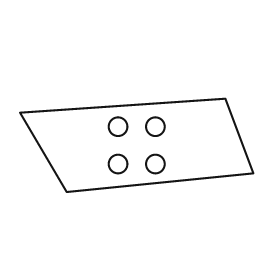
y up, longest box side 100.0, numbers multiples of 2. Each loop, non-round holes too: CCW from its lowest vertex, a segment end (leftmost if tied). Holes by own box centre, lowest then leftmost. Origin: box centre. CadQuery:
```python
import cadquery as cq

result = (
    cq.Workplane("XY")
    .moveTo(-30.0, -20.0)
    .lineTo(50.0, -12.0)
    .lineTo(38.0, 20.0)
    .lineTo(-50.0, 14.0)
    .close()
    .moveTo(-8.0, -8.0)
    .circle(4.0)
    .moveTo(8.0, -8.0)
    .circle(4.0)
    .moveTo(-8.0, 8.0)
    .circle(4.0)
    .moveTo(8.0, 8.0)
    .circle(4.0)
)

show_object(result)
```